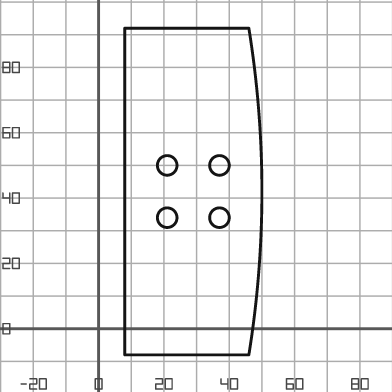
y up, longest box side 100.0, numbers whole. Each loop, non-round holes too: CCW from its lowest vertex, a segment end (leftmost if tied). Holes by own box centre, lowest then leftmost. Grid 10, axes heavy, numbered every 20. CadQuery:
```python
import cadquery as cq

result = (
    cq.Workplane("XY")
    .moveTo(8.0, -8.0)
    .lineTo(46.0, -8.0)
    .threePointArc((50.0, 42.0), (46.0, 92.0))
    .lineTo(8.0, 92.0)
    .close()
    .moveTo(21.0, 34.0)
    .circle(3.0)
    .moveTo(37.0, 34.0)
    .circle(3.0)
    .moveTo(21.0, 50.0)
    .circle(3.0)
    .moveTo(37.0, 50.0)
    .circle(3.0)
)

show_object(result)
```